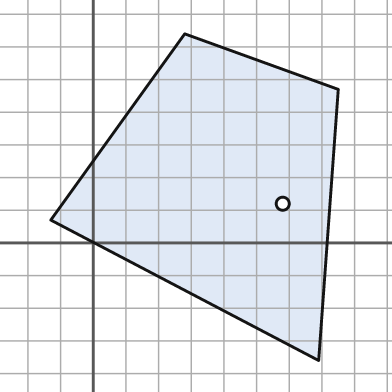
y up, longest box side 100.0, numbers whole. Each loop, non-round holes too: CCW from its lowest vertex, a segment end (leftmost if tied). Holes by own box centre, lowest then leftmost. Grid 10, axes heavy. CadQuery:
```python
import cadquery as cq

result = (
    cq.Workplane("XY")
    .moveTo(69.0, -36.0)
    .lineTo(75.0, 47.0)
    .lineTo(28.0, 64.0)
    .lineTo(-13.0, 7.0)
    .close()
    .moveTo(58.0, 12.0)
    .circle(2.0)
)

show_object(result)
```